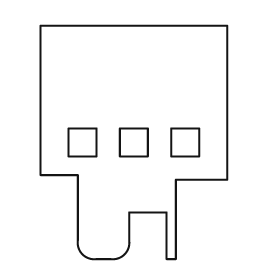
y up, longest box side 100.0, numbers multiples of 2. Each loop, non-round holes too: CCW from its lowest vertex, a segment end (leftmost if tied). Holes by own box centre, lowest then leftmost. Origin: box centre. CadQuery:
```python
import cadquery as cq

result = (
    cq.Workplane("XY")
    .moveTo(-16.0, -50.0)
    .lineTo(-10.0, -50.0)
    .threePointArc((-4.0, -48.0), (-2.0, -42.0))
    .lineTo(-2.0, -30.0)
    .lineTo(14.0, -30.0)
    .lineTo(14.0, -50.0)
    .lineTo(18.0, -50.0)
    .lineTo(18.0, -16.0)
    .lineTo(40.0, -16.0)
    .lineTo(40.0, 50.0)
    .lineTo(-40.0, 50.0)
    .lineTo(-40.0, -14.0)
    .lineTo(-24.0, -14.0)
    .lineTo(-24.0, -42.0)
    .threePointArc((-22.0, -48.0), (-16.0, -50.0))
    .close()
    .moveTo(-28.0, -6.0)
    .lineTo(-16.0, -6.0)
    .lineTo(-16.0, 6.0)
    .lineTo(-28.0, 6.0)
    .close()
    .moveTo(-6.0, -6.0)
    .lineTo(6.0, -6.0)
    .lineTo(6.0, 6.0)
    .lineTo(-6.0, 6.0)
    .close()
    .moveTo(16.0, -6.0)
    .lineTo(28.0, -6.0)
    .lineTo(28.0, 6.0)
    .lineTo(16.0, 6.0)
    .close()
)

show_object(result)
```